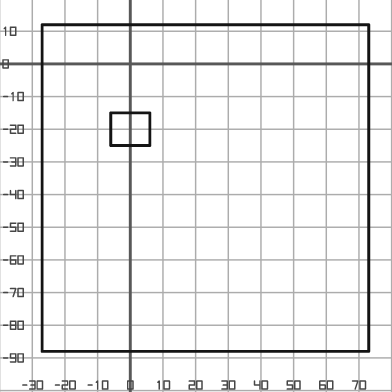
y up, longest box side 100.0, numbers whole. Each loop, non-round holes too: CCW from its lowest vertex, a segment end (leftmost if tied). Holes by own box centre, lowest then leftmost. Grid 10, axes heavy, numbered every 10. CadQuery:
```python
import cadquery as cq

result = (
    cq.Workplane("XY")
    .moveTo(-27.0, -88.0)
    .lineTo(73.0, -88.0)
    .lineTo(73.0, 12.0)
    .lineTo(-27.0, 12.0)
    .close()
    .moveTo(-6.0, -25.0)
    .lineTo(6.0, -25.0)
    .lineTo(6.0, -15.0)
    .lineTo(-6.0, -15.0)
    .close()
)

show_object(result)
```